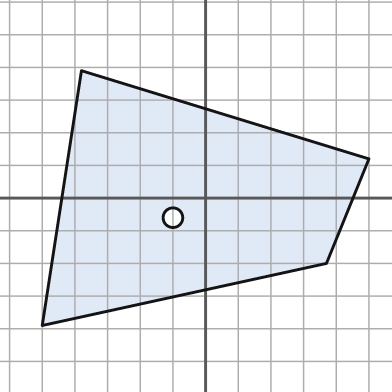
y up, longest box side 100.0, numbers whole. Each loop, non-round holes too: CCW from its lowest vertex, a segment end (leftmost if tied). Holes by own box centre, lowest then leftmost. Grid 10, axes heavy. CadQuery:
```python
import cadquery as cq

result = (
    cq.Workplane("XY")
    .moveTo(-50.0, -39.0)
    .lineTo(37.0, -20.0)
    .lineTo(50.0, 12.0)
    .lineTo(-38.0, 39.0)
    .close()
    .moveTo(-10.0, -6.0)
    .circle(3.0)
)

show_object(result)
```